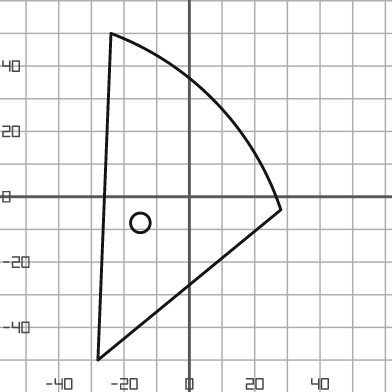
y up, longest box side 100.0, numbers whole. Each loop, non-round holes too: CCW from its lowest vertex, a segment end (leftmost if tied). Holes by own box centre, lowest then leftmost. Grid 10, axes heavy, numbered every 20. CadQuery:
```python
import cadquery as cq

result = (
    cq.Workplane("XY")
    .moveTo(-28.0, -50.0)
    .lineTo(28.0, -4.0)
    .threePointArc((8.0, 29.0), (-24.0, 50.0))
    .close()
    .moveTo(-15.0, -8.0)
    .circle(3.0)
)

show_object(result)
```